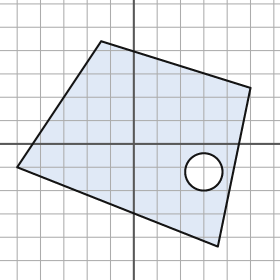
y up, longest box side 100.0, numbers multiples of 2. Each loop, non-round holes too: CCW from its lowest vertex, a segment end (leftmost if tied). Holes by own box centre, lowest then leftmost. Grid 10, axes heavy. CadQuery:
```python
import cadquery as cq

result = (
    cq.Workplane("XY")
    .moveTo(36.0, -44.0)
    .lineTo(50.0, 24.0)
    .lineTo(-14.0, 44.0)
    .lineTo(-50.0, -10.0)
    .close()
    .moveTo(30.0, -12.0)
    .circle(8.0)
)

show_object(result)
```